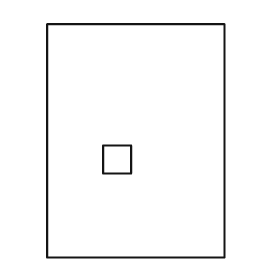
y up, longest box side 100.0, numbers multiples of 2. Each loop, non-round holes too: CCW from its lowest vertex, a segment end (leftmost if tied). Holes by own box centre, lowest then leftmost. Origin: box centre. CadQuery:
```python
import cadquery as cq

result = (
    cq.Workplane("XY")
    .moveTo(-38.0, -50.0)
    .lineTo(38.0, -50.0)
    .lineTo(38.0, 50.0)
    .lineTo(-38.0, 50.0)
    .close()
    .moveTo(-14.0, -14.0)
    .lineTo(-2.0, -14.0)
    .lineTo(-2.0, -2.0)
    .lineTo(-14.0, -2.0)
    .close()
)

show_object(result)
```